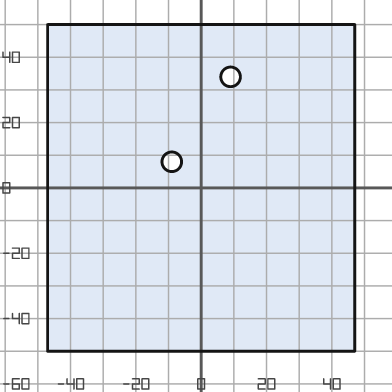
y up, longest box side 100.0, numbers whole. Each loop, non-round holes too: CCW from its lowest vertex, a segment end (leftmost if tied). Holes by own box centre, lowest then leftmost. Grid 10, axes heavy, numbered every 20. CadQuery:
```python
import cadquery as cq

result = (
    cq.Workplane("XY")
    .moveTo(-47.0, -50.0)
    .lineTo(47.0, -50.0)
    .lineTo(47.0, 50.0)
    .lineTo(-47.0, 50.0)
    .close()
    .moveTo(-9.0, 8.0)
    .circle(3.0)
    .moveTo(9.0, 34.0)
    .circle(3.0)
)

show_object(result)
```